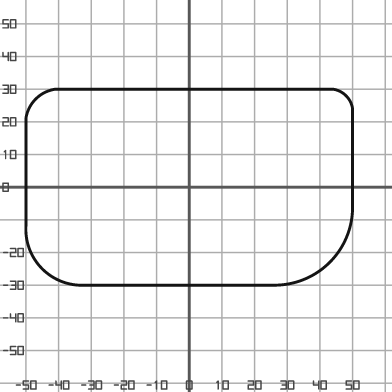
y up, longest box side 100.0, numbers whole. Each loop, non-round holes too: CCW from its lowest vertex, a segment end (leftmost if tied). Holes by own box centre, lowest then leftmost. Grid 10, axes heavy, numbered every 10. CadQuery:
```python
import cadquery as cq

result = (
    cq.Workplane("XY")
    .moveTo(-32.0, -30.0)
    .lineTo(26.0, -30.0)
    .threePointArc((43.0, -23.0), (50.0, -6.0))
    .lineTo(50.0, 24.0)
    .threePointArc((48.0, 28.0), (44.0, 30.0))
    .lineTo(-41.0, 30.0)
    .threePointArc((-47.0, 27.0), (-50.0, 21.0))
    .lineTo(-50.0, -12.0)
    .threePointArc((-45.0, -25.0), (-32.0, -30.0))
    .close()
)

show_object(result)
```